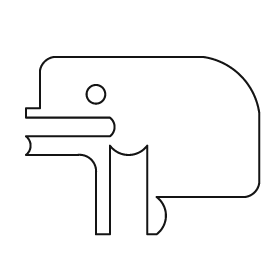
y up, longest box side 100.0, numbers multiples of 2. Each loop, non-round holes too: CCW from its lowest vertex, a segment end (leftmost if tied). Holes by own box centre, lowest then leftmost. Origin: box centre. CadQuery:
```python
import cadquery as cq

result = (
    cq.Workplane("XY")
    .moveTo(-20.0, -38.0)
    .lineTo(-14.0, -38.0)
    .lineTo(-14.0, 0.0)
    .threePointArc((-6.0, -4.0), (2.0, 0.0))
    .lineTo(2.0, -38.0)
    .lineTo(6.0, -38.0)
    .threePointArc((10.0, -30.0), (6.0, -22.0))
    .lineTo(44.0, -22.0)
    .threePointArc((48.0, -20.0), (50.0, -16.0))
    .lineTo(50.0, 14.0)
    .threePointArc((42.0, 30.0), (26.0, 38.0))
    .lineTo(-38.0, 38.0)
    .threePointArc((-42.0, 36.0), (-44.0, 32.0))
    .lineTo(-44.0, 16.0)
    .lineTo(-50.0, 16.0)
    .lineTo(-50.0, 12.0)
    .lineTo(-14.0, 12.0)
    .threePointArc((-12.0, 8.0), (-14.0, 4.0))
    .lineTo(-50.0, 4.0)
    .threePointArc((-48.0, 0.0), (-50.0, -4.0))
    .lineTo(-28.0, -4.0)
    .threePointArc((-22.0, -6.0), (-20.0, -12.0))
    .close()
    .moveTo(-20.0, 22.0)
    .circle(4.0)
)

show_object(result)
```